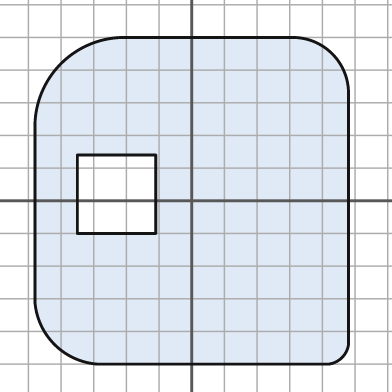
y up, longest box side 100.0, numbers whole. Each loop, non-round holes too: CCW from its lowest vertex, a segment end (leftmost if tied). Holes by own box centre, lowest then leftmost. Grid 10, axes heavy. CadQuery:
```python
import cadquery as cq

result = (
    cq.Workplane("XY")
    .moveTo(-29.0, -50.0)
    .lineTo(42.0, -50.0)
    .threePointArc((46.0, -48.0), (48.0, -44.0))
    .lineTo(48.0, 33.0)
    .threePointArc((43.0, 45.0), (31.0, 50.0))
    .lineTo(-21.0, 50.0)
    .threePointArc((-40.0, 42.0), (-48.0, 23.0))
    .lineTo(-48.0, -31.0)
    .threePointArc((-42.0, -44.0), (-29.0, -50.0))
    .close()
    .moveTo(-35.0, -10.0)
    .lineTo(-11.0, -10.0)
    .lineTo(-11.0, 14.0)
    .lineTo(-35.0, 14.0)
    .close()
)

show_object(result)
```